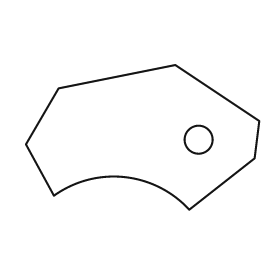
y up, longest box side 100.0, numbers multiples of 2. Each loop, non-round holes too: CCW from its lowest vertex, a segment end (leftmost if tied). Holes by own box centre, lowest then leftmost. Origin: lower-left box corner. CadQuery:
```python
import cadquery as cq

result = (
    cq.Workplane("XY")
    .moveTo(70.0, 0.0)
    .lineTo(98.0, 22.0)
    .lineTo(100.0, 38.0)
    .lineTo(64.0, 62.0)
    .lineTo(14.0, 52.0)
    .lineTo(0.0, 28.0)
    .lineTo(12.0, 6.0)
    .threePointArc((42.0, 14.0), (70.0, 0.0))
    .close()
    .moveTo(74.0, 30.0)
    .circle(6.0)
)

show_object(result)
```